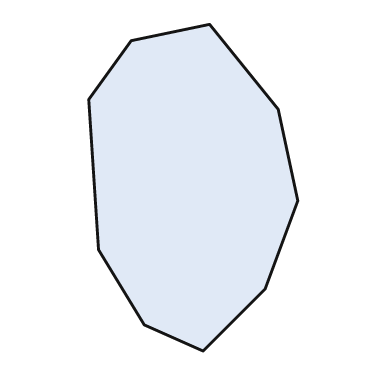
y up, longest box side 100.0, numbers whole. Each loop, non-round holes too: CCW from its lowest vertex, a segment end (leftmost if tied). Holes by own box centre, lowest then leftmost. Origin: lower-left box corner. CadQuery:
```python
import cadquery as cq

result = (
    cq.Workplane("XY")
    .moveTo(35.0, 0.0)
    .lineTo(54.0, 19.0)
    .lineTo(64.0, 46.0)
    .lineTo(58.0, 74.0)
    .lineTo(37.0, 100.0)
    .lineTo(13.0, 95.0)
    .lineTo(0.0, 77.0)
    .lineTo(3.0, 31.0)
    .lineTo(17.0, 8.0)
    .close()
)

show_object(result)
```